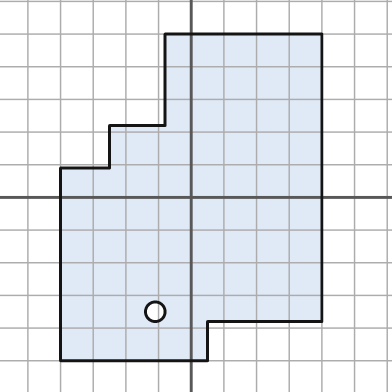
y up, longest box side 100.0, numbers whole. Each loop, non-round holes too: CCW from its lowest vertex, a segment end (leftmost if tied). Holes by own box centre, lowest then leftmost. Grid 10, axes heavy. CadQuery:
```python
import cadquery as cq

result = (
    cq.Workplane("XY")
    .moveTo(-40.0, -50.0)
    .lineTo(5.0, -50.0)
    .lineTo(5.0, -38.0)
    .lineTo(40.0, -38.0)
    .lineTo(40.0, 50.0)
    .lineTo(-8.0, 50.0)
    .lineTo(-8.0, 22.0)
    .lineTo(-25.0, 22.0)
    .lineTo(-25.0, 9.0)
    .lineTo(-40.0, 9.0)
    .close()
    .moveTo(-11.0, -35.0)
    .circle(3.0)
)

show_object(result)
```